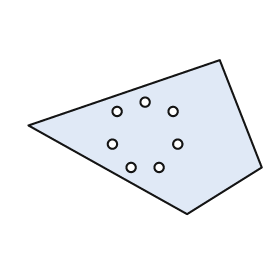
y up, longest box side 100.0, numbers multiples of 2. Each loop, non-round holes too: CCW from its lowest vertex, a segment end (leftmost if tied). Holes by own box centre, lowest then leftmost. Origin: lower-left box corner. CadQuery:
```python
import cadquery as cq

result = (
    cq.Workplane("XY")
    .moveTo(68.0, 0.0)
    .lineTo(100.0, 20.0)
    .lineTo(82.0, 66.0)
    .lineTo(0.0, 38.0)
    .close()
    .moveTo(44.0, 20.0)
    .circle(2.0)
    .moveTo(56.0, 20.0)
    .circle(2.0)
    .moveTo(36.0, 30.0)
    .circle(2.0)
    .moveTo(64.0, 30.0)
    .circle(2.0)
    .moveTo(38.0, 44.0)
    .circle(2.0)
    .moveTo(62.0, 44.0)
    .circle(2.0)
    .moveTo(50.0, 48.0)
    .circle(2.0)
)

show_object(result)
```